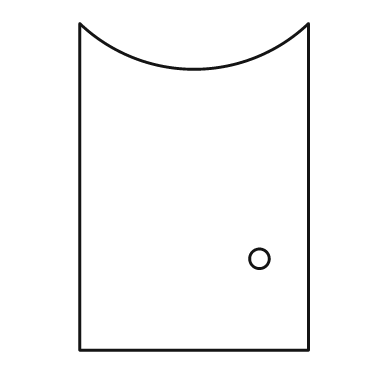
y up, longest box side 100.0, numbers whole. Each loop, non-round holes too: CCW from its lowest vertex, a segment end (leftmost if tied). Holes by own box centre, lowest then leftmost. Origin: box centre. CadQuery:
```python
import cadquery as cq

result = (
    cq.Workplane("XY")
    .moveTo(-35.0, -50.0)
    .lineTo(35.0, -50.0)
    .lineTo(35.0, 50.0)
    .threePointArc((0.0, 36.0), (-35.0, 50.0))
    .close()
    .moveTo(20.0, -22.0)
    .circle(3.0)
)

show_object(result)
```